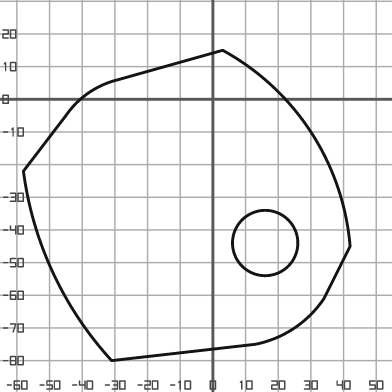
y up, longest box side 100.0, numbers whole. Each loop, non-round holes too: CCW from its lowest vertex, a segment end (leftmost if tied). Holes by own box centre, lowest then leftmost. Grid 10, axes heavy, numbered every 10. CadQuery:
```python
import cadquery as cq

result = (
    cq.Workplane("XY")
    .moveTo(-31.0, -80.0)
    .lineTo(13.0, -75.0)
    .threePointArc((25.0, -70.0), (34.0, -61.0))
    .lineTo(42.0, -45.0)
    .threePointArc((30.0, -10.0), (3.0, 15.0))
    .lineTo(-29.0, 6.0)
    .threePointArc((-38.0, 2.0), (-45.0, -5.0))
    .lineTo(-58.0, -22.0)
    .threePointArc((-49.0, -53.0), (-31.0, -80.0))
    .close()
    .moveTo(16.0, -44.0)
    .circle(10.0)
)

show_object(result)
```